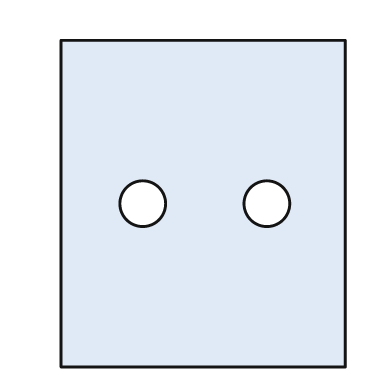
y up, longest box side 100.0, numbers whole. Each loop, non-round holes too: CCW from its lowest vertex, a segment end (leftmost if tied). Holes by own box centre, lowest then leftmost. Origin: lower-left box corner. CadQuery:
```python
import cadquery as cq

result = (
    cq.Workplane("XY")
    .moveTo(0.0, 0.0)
    .lineTo(87.0, 0.0)
    .lineTo(87.0, 100.0)
    .lineTo(0.0, 100.0)
    .close()
    .moveTo(25.0, 50.0)
    .circle(7.0)
    .moveTo(63.0, 50.0)
    .circle(7.0)
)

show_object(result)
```